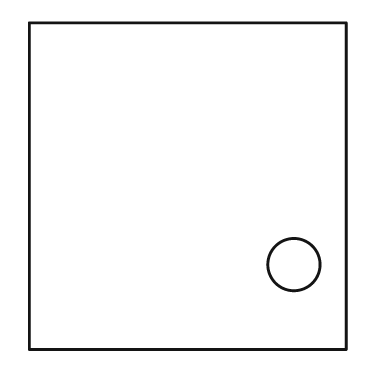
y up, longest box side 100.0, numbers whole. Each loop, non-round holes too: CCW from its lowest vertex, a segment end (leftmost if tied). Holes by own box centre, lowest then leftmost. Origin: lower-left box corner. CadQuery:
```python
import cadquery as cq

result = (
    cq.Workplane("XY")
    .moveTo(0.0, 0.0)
    .lineTo(97.0, 0.0)
    .lineTo(97.0, 100.0)
    .lineTo(0.0, 100.0)
    .close()
    .moveTo(81.0, 26.0)
    .circle(8.0)
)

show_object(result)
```